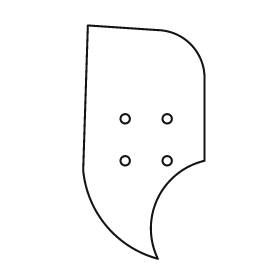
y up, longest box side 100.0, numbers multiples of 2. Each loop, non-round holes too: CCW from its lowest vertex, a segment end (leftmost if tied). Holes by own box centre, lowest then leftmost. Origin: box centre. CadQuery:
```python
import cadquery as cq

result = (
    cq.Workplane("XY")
    .moveTo(6.0, -50.0)
    .threePointArc((6.0, -24.0), (26.0, -8.0))
    .lineTo(26.0, 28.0)
    .threePointArc((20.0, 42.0), (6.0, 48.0))
    .lineTo(-24.0, 50.0)
    .lineTo(-26.0, -12.0)
    .threePointArc((-16.0, -36.0), (6.0, -50.0))
    .close()
    .moveTo(-8.0, -8.0)
    .circle(2.0)
    .moveTo(10.0, -8.0)
    .circle(2.0)
    .moveTo(-8.0, 10.0)
    .circle(2.0)
    .moveTo(10.0, 10.0)
    .circle(2.0)
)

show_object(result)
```